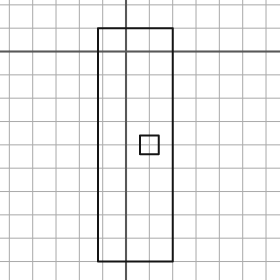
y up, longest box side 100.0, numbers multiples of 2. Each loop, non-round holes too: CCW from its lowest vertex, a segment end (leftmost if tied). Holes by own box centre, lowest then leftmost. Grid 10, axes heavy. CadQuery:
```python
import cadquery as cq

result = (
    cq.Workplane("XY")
    .moveTo(-12.0, -90.0)
    .lineTo(20.0, -90.0)
    .lineTo(20.0, 10.0)
    .lineTo(-12.0, 10.0)
    .close()
    .moveTo(6.0, -44.0)
    .lineTo(14.0, -44.0)
    .lineTo(14.0, -36.0)
    .lineTo(6.0, -36.0)
    .close()
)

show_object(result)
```